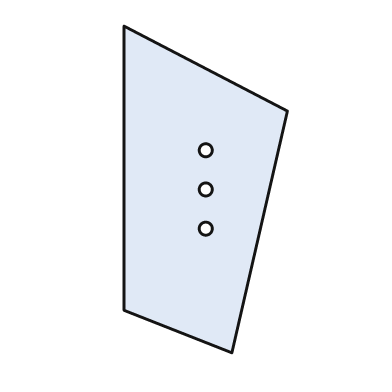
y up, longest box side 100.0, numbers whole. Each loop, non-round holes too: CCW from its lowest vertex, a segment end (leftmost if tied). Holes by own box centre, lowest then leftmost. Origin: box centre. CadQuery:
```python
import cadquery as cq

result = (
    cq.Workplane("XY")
    .moveTo(8.0, -50.0)
    .lineTo(25.0, 24.0)
    .lineTo(-25.0, 50.0)
    .lineTo(-25.0, -37.0)
    .close()
    .moveTo(0.0, -12.0)
    .circle(2.0)
    .moveTo(0.0, 0.0)
    .circle(2.0)
    .moveTo(0.0, 12.0)
    .circle(2.0)
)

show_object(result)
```